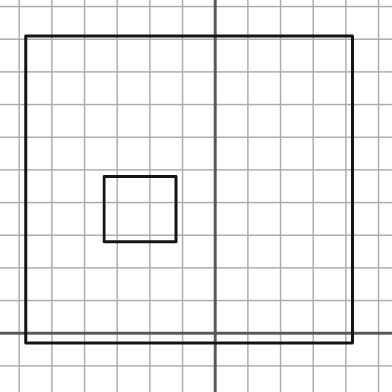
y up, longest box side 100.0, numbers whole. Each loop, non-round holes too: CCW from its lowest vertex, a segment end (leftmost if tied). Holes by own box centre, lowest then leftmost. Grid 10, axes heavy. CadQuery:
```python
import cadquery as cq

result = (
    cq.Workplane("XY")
    .moveTo(-58.0, -3.0)
    .lineTo(42.0, -3.0)
    .lineTo(42.0, 91.0)
    .lineTo(-58.0, 91.0)
    .close()
    .moveTo(-34.0, 28.0)
    .lineTo(-12.0, 28.0)
    .lineTo(-12.0, 48.0)
    .lineTo(-34.0, 48.0)
    .close()
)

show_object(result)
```